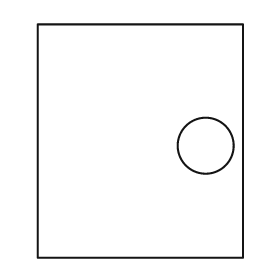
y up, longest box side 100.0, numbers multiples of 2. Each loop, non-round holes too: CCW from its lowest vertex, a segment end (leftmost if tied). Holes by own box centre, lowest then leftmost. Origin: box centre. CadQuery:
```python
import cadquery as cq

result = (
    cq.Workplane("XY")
    .moveTo(-44.0, -50.0)
    .lineTo(44.0, -50.0)
    .lineTo(44.0, 50.0)
    .lineTo(-44.0, 50.0)
    .close()
    .moveTo(28.0, -2.0)
    .circle(12.0)
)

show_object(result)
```